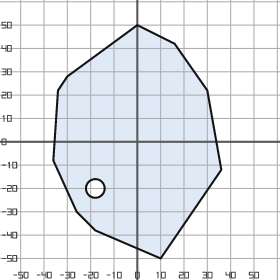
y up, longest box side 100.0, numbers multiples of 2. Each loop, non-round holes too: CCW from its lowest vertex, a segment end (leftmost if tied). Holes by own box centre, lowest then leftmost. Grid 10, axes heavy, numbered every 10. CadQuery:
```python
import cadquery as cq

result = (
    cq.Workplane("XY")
    .moveTo(10.0, -50.0)
    .lineTo(36.0, -12.0)
    .lineTo(30.0, 22.0)
    .lineTo(16.0, 42.0)
    .lineTo(0.0, 50.0)
    .lineTo(-30.0, 28.0)
    .lineTo(-34.0, 22.0)
    .lineTo(-36.0, -8.0)
    .lineTo(-26.0, -30.0)
    .lineTo(-18.0, -38.0)
    .close()
    .moveTo(-18.0, -20.0)
    .circle(4.0)
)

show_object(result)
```